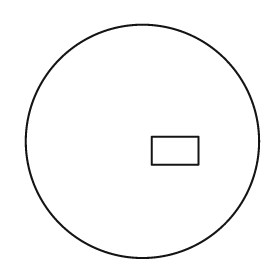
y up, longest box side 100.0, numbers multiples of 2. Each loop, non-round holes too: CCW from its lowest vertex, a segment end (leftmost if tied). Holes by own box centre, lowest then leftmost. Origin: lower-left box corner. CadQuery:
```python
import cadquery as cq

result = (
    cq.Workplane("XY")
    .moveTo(50.0, 50.0)
    .circle(50.0)
    .moveTo(54.0, 40.0)
    .lineTo(74.0, 40.0)
    .lineTo(74.0, 52.0)
    .lineTo(54.0, 52.0)
    .close()
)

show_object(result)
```